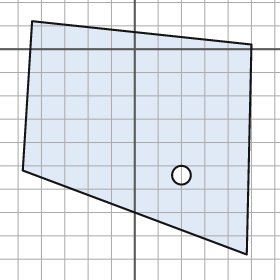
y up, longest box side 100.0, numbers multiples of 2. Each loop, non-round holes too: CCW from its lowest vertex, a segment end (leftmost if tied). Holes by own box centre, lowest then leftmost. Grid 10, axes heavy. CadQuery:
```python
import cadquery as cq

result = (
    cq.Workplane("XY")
    .moveTo(48.0, -88.0)
    .lineTo(50.0, 2.0)
    .lineTo(-44.0, 12.0)
    .lineTo(-48.0, -52.0)
    .close()
    .moveTo(20.0, -54.0)
    .circle(4.0)
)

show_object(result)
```